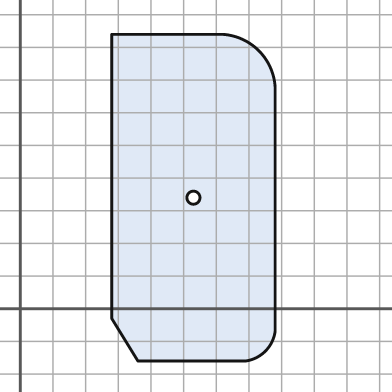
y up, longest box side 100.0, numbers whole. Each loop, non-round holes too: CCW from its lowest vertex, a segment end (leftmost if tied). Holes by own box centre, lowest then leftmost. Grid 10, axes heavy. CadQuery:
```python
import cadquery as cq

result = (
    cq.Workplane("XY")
    .moveTo(36.0, -16.0)
    .lineTo(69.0, -16.0)
    .threePointArc((75.0, -13.0), (78.0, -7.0))
    .lineTo(78.0, 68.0)
    .threePointArc((73.0, 79.0), (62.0, 84.0))
    .lineTo(28.0, 84.0)
    .lineTo(28.0, -3.0)
    .close()
    .moveTo(53.0, 34.0)
    .circle(2.0)
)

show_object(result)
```